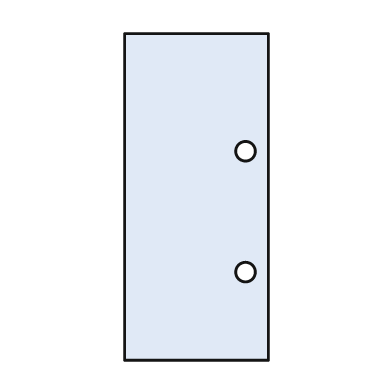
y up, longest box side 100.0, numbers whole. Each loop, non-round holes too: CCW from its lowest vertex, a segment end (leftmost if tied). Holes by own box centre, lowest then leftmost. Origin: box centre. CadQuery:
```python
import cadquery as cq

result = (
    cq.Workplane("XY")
    .moveTo(-22.0, -50.0)
    .lineTo(22.0, -50.0)
    .lineTo(22.0, 50.0)
    .lineTo(-22.0, 50.0)
    .close()
    .moveTo(15.0, -23.0)
    .circle(3.0)
    .moveTo(15.0, 14.0)
    .circle(3.0)
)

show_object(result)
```